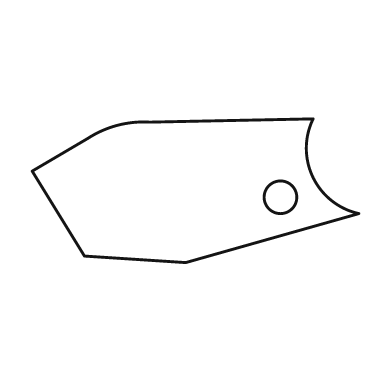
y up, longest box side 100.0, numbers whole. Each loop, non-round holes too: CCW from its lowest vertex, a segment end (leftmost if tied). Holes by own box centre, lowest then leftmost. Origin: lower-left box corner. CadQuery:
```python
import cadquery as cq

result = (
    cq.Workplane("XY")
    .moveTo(47.0, 0.0)
    .lineTo(100.0, 15.0)
    .threePointArc((86.0, 26.0), (86.0, 44.0))
    .lineTo(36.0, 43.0)
    .threePointArc((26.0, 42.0), (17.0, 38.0))
    .lineTo(0.0, 28.0)
    .lineTo(16.0, 2.0)
    .close()
    .moveTo(76.0, 20.0)
    .circle(5.0)
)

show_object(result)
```